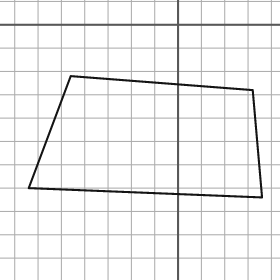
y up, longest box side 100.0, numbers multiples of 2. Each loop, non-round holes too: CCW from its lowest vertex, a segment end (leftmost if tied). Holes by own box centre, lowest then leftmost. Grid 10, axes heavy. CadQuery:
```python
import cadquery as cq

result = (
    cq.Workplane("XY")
    .moveTo(36.0, -74.0)
    .lineTo(32.0, -28.0)
    .lineTo(-46.0, -22.0)
    .lineTo(-64.0, -70.0)
    .close()
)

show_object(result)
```